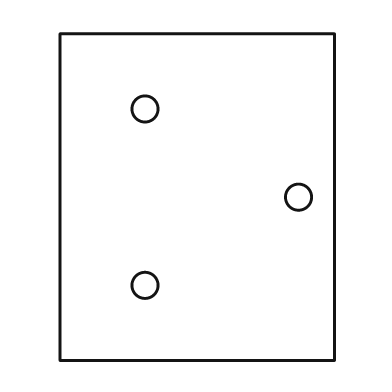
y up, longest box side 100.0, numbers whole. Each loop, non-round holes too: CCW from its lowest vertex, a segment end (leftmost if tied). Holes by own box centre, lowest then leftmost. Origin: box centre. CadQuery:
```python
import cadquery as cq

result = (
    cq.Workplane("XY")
    .moveTo(-42.0, -50.0)
    .lineTo(42.0, -50.0)
    .lineTo(42.0, 50.0)
    .lineTo(-42.0, 50.0)
    .close()
    .moveTo(-16.0, -27.0)
    .circle(4.0)
    .moveTo(31.0, 0.0)
    .circle(4.0)
    .moveTo(-16.0, 27.0)
    .circle(4.0)
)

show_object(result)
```